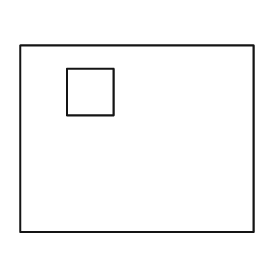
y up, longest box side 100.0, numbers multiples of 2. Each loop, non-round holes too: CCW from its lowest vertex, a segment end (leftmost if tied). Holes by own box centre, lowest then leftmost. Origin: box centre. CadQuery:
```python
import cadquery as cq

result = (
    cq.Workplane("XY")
    .moveTo(-50.0, -40.0)
    .lineTo(50.0, -40.0)
    .lineTo(50.0, 40.0)
    .lineTo(-50.0, 40.0)
    .close()
    .moveTo(-30.0, 10.0)
    .lineTo(-10.0, 10.0)
    .lineTo(-10.0, 30.0)
    .lineTo(-30.0, 30.0)
    .close()
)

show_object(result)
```